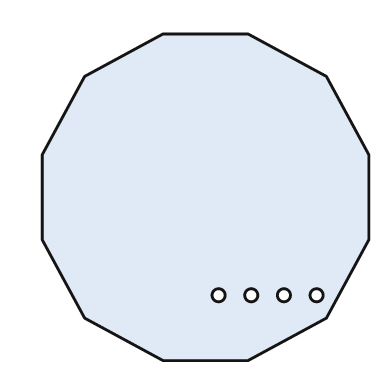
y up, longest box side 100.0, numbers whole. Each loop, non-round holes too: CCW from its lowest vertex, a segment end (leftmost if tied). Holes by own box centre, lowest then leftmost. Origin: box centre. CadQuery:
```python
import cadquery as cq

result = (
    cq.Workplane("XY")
    .moveTo(-13.0, -50.0)
    .lineTo(13.0, -50.0)
    .lineTo(37.0, -37.0)
    .lineTo(50.0, -13.0)
    .lineTo(50.0, 13.0)
    .lineTo(37.0, 37.0)
    .lineTo(13.0, 50.0)
    .lineTo(-13.0, 50.0)
    .lineTo(-37.0, 37.0)
    .lineTo(-50.0, 13.0)
    .lineTo(-50.0, -13.0)
    .lineTo(-37.0, -37.0)
    .close()
    .moveTo(4.0, -30.0)
    .circle(2.0)
    .moveTo(14.0, -30.0)
    .circle(2.0)
    .moveTo(24.0, -30.0)
    .circle(2.0)
    .moveTo(34.0, -30.0)
    .circle(2.0)
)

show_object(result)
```